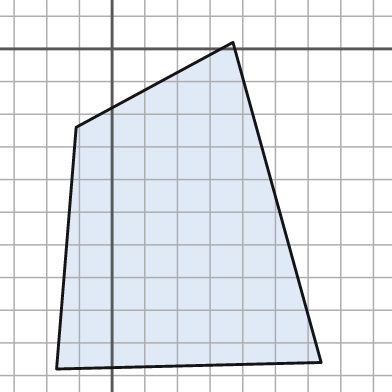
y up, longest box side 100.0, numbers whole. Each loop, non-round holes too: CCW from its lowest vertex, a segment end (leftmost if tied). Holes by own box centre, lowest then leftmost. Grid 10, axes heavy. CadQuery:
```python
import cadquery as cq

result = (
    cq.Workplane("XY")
    .moveTo(-17.0, -98.0)
    .lineTo(64.0, -96.0)
    .lineTo(37.0, 2.0)
    .lineTo(-11.0, -24.0)
    .close()
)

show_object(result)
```